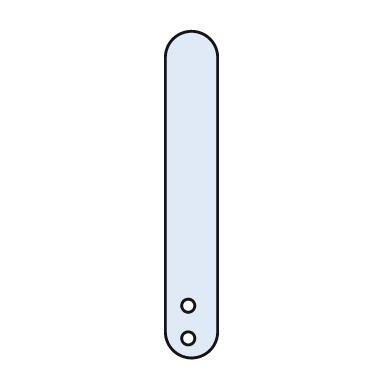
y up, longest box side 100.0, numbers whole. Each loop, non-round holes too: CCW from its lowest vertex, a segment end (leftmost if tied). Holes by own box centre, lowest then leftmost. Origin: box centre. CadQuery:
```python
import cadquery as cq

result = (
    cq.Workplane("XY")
    .moveTo(-8.0, -42.0)
    .threePointArc((0.0, -50.0), (8.0, -42.0))
    .lineTo(8.0, 42.0)
    .threePointArc((0.0, 50.0), (-8.0, 42.0))
    .close()
    .moveTo(-1.0, -44.0)
    .circle(2.0)
    .moveTo(-1.0, -34.0)
    .circle(2.0)
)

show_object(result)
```